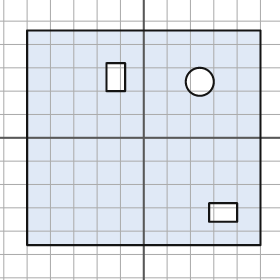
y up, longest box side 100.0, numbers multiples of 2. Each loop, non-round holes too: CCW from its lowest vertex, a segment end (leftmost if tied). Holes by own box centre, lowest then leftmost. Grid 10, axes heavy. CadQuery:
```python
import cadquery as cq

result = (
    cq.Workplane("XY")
    .moveTo(-50.0, -46.0)
    .lineTo(50.0, -46.0)
    .lineTo(50.0, 46.0)
    .lineTo(-50.0, 46.0)
    .close()
    .moveTo(28.0, -36.0)
    .lineTo(40.0, -36.0)
    .lineTo(40.0, -28.0)
    .lineTo(28.0, -28.0)
    .close()
    .moveTo(24.0, 24.0)
    .circle(6.0)
    .moveTo(-16.0, 20.0)
    .lineTo(-8.0, 20.0)
    .lineTo(-8.0, 32.0)
    .lineTo(-16.0, 32.0)
    .close()
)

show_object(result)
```